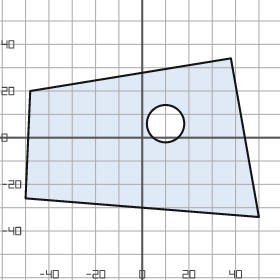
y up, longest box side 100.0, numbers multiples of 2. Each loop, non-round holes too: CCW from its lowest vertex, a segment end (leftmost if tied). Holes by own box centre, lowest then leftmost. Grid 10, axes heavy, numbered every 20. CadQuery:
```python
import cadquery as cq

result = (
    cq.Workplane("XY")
    .moveTo(50.0, -34.0)
    .lineTo(38.0, 34.0)
    .lineTo(-48.0, 20.0)
    .lineTo(-50.0, -26.0)
    .close()
    .moveTo(10.0, 6.0)
    .circle(8.0)
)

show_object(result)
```